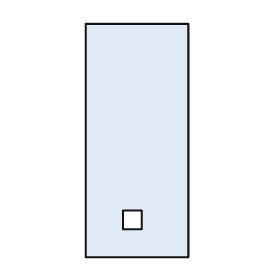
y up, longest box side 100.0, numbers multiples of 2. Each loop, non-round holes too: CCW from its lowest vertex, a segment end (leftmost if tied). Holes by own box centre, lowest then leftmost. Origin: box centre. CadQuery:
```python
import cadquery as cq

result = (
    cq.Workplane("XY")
    .moveTo(-22.0, -50.0)
    .lineTo(22.0, -50.0)
    .lineTo(22.0, 50.0)
    .lineTo(-22.0, 50.0)
    .close()
    .moveTo(-6.0, -38.0)
    .lineTo(2.0, -38.0)
    .lineTo(2.0, -30.0)
    .lineTo(-6.0, -30.0)
    .close()
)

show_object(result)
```